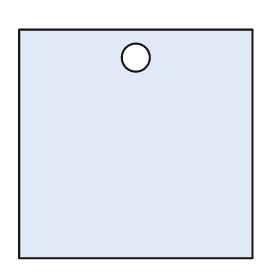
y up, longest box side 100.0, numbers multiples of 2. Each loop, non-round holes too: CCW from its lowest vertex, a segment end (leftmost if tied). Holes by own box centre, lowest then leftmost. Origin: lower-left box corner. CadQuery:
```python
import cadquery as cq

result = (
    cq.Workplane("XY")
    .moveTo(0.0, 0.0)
    .lineTo(100.0, 0.0)
    .lineTo(100.0, 98.0)
    .lineTo(0.0, 98.0)
    .close()
    .moveTo(50.0, 86.0)
    .circle(6.0)
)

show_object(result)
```